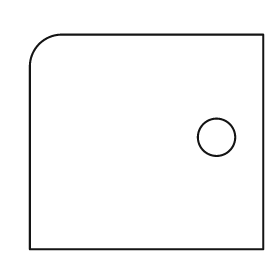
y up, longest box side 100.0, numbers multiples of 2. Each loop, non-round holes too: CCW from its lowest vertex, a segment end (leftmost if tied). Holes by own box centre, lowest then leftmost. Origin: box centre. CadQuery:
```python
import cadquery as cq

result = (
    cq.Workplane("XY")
    .moveTo(-50.0, -46.0)
    .lineTo(50.0, -46.0)
    .lineTo(50.0, 46.0)
    .lineTo(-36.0, 46.0)
    .threePointArc((-46.0, 42.0), (-50.0, 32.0))
    .close()
    .moveTo(30.0, 2.0)
    .circle(8.0)
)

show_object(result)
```